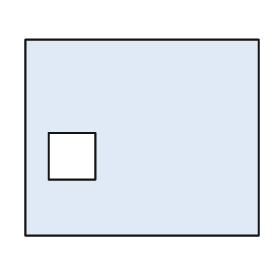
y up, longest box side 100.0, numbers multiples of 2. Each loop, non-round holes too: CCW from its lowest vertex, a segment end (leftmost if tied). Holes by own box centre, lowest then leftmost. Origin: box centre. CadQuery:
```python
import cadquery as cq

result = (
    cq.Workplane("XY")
    .moveTo(-50.0, -42.0)
    .lineTo(50.0, -42.0)
    .lineTo(50.0, 42.0)
    .lineTo(-50.0, 42.0)
    .close()
    .moveTo(-40.0, -18.0)
    .lineTo(-20.0, -18.0)
    .lineTo(-20.0, 2.0)
    .lineTo(-40.0, 2.0)
    .close()
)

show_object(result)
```